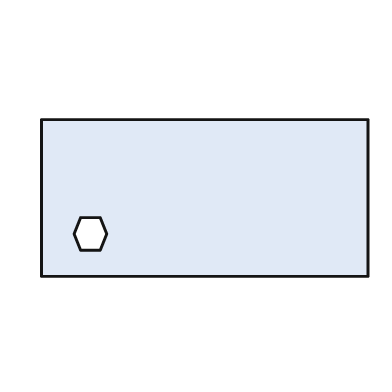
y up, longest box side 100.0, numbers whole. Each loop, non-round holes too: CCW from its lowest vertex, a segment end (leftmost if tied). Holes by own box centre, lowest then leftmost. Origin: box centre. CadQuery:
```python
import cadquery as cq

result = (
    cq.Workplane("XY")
    .moveTo(-50.0, -24.0)
    .lineTo(50.0, -24.0)
    .lineTo(50.0, 24.0)
    .lineTo(-50.0, 24.0)
    .close()
    .moveTo(-38.0, -16.0)
    .lineTo(-32.0, -16.0)
    .lineTo(-30.0, -11.0)
    .lineTo(-32.0, -6.0)
    .lineTo(-38.0, -6.0)
    .lineTo(-40.0, -11.0)
    .close()
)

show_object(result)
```